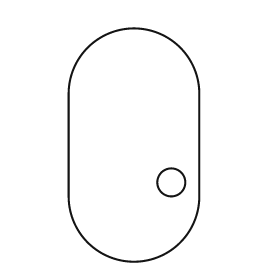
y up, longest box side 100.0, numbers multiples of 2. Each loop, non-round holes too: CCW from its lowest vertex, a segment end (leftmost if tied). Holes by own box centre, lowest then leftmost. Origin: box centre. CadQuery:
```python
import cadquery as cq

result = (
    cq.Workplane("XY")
    .moveTo(-28.0, -22.0)
    .threePointArc((0.0, -50.0), (28.0, -22.0))
    .lineTo(28.0, 22.0)
    .threePointArc((0.0, 50.0), (-28.0, 22.0))
    .close()
    .moveTo(16.0, -16.0)
    .circle(6.0)
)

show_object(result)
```